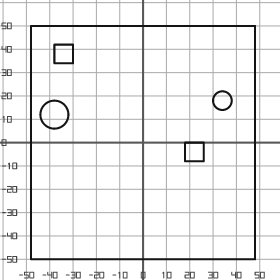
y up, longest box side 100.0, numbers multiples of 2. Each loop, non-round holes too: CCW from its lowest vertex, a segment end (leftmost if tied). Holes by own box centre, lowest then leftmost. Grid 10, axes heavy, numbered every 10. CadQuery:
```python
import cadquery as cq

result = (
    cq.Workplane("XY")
    .moveTo(-48.0, -50.0)
    .lineTo(48.0, -50.0)
    .lineTo(48.0, 50.0)
    .lineTo(-48.0, 50.0)
    .close()
    .moveTo(18.0, -8.0)
    .lineTo(26.0, -8.0)
    .lineTo(26.0, 0.0)
    .lineTo(18.0, 0.0)
    .close()
    .moveTo(-38.0, 12.0)
    .circle(6.0)
    .moveTo(34.0, 18.0)
    .circle(4.0)
    .moveTo(-38.0, 34.0)
    .lineTo(-30.0, 34.0)
    .lineTo(-30.0, 42.0)
    .lineTo(-38.0, 42.0)
    .close()
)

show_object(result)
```